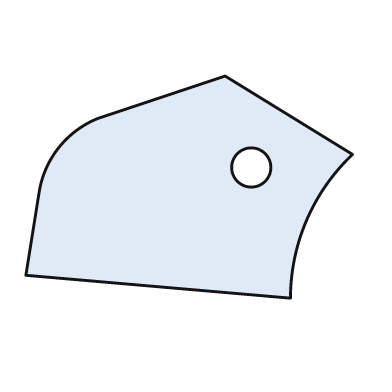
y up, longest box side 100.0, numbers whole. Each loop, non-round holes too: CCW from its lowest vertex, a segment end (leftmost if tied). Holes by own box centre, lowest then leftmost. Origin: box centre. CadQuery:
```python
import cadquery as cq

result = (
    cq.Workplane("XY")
    .moveTo(31.0, -34.0)
    .threePointArc((36.0, -10.0), (50.0, 10.0))
    .lineTo(11.0, 34.0)
    .lineTo(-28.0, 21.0)
    .threePointArc((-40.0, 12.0), (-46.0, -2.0))
    .lineTo(-50.0, -27.0)
    .close()
    .moveTo(19.0, 6.0)
    .circle(6.0)
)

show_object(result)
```